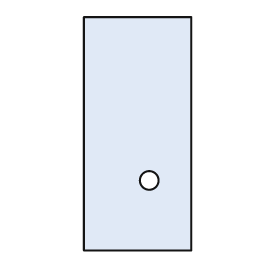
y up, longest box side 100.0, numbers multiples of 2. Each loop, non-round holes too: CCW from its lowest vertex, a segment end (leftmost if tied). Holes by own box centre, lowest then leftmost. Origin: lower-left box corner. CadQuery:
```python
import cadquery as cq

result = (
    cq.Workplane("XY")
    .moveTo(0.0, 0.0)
    .lineTo(46.0, 0.0)
    .lineTo(46.0, 100.0)
    .lineTo(0.0, 100.0)
    .close()
    .moveTo(28.0, 30.0)
    .circle(4.0)
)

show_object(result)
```